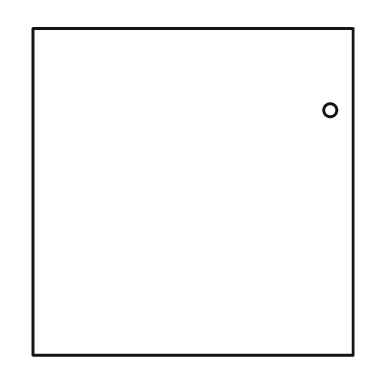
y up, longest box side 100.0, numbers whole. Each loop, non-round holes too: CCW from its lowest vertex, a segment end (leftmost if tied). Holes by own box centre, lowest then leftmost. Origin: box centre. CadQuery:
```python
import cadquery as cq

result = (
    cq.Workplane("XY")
    .moveTo(-49.0, -50.0)
    .lineTo(49.0, -50.0)
    .lineTo(49.0, 50.0)
    .lineTo(-49.0, 50.0)
    .close()
    .moveTo(42.0, 25.0)
    .circle(2.0)
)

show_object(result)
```